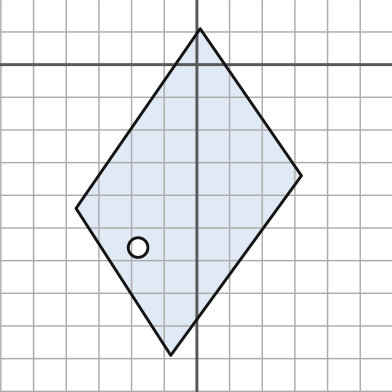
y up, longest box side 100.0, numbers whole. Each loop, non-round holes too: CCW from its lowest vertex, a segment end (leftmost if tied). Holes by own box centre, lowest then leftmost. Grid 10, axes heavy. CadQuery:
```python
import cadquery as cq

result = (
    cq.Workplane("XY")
    .moveTo(-8.0, -89.0)
    .lineTo(32.0, -34.0)
    .lineTo(1.0, 11.0)
    .lineTo(-37.0, -44.0)
    .close()
    .moveTo(-18.0, -56.0)
    .circle(3.0)
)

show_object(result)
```